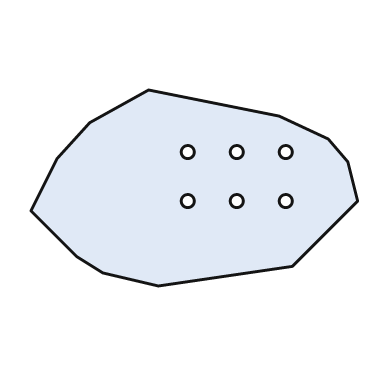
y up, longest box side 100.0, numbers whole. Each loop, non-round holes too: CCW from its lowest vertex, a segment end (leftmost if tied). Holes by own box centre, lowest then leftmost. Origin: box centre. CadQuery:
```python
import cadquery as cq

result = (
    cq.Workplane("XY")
    .moveTo(-11.0, -30.0)
    .lineTo(30.0, -24.0)
    .lineTo(50.0, -4.0)
    .lineTo(47.0, 8.0)
    .lineTo(41.0, 15.0)
    .lineTo(26.0, 22.0)
    .lineTo(-14.0, 30.0)
    .lineTo(-32.0, 20.0)
    .lineTo(-42.0, 9.0)
    .lineTo(-50.0, -7.0)
    .lineTo(-36.0, -21.0)
    .lineTo(-28.0, -26.0)
    .close()
    .moveTo(-2.0, -4.0)
    .circle(2.0)
    .moveTo(13.0, -4.0)
    .circle(2.0)
    .moveTo(28.0, -4.0)
    .circle(2.0)
    .moveTo(-2.0, 11.0)
    .circle(2.0)
    .moveTo(13.0, 11.0)
    .circle(2.0)
    .moveTo(28.0, 11.0)
    .circle(2.0)
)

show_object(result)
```